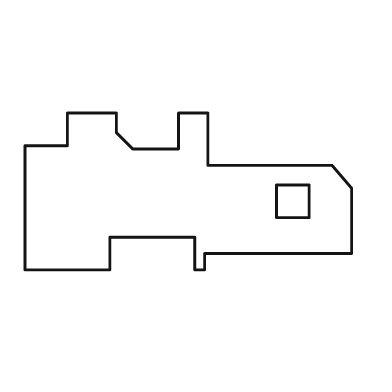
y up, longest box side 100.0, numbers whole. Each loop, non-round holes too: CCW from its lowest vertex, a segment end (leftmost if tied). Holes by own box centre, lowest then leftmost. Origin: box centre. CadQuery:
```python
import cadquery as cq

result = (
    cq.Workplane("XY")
    .moveTo(-50.0, -24.0)
    .lineTo(-24.0, -24.0)
    .lineTo(-24.0, -14.0)
    .lineTo(2.0, -14.0)
    .lineTo(2.0, -24.0)
    .lineTo(5.0, -24.0)
    .lineTo(5.0, -19.0)
    .lineTo(50.0, -19.0)
    .lineTo(50.0, 1.0)
    .lineTo(44.0, 8.0)
    .lineTo(6.0, 8.0)
    .lineTo(6.0, 24.0)
    .lineTo(-3.0, 24.0)
    .lineTo(-3.0, 13.0)
    .lineTo(-17.0, 13.0)
    .lineTo(-22.0, 18.0)
    .lineTo(-22.0, 24.0)
    .lineTo(-37.0, 24.0)
    .lineTo(-37.0, 14.0)
    .lineTo(-50.0, 14.0)
    .close()
    .moveTo(27.0, -8.0)
    .lineTo(37.0, -8.0)
    .lineTo(37.0, 2.0)
    .lineTo(27.0, 2.0)
    .close()
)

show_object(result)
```